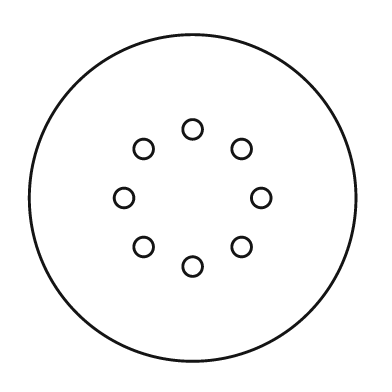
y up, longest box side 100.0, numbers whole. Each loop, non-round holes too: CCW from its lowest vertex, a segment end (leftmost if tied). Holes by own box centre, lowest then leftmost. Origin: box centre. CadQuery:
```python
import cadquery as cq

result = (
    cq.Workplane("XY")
    .moveTo(0.0, 0.0)
    .circle(50.0)
    .moveTo(0.0, -21.0)
    .circle(3.0)
    .moveTo(-15.0, -15.0)
    .circle(3.0)
    .moveTo(15.0, -15.0)
    .circle(3.0)
    .moveTo(-21.0, 0.0)
    .circle(3.0)
    .moveTo(21.0, 0.0)
    .circle(3.0)
    .moveTo(-15.0, 15.0)
    .circle(3.0)
    .moveTo(15.0, 15.0)
    .circle(3.0)
    .moveTo(0.0, 21.0)
    .circle(3.0)
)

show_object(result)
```